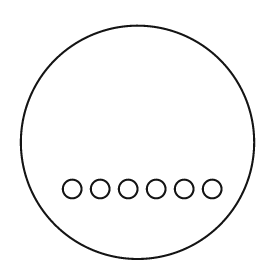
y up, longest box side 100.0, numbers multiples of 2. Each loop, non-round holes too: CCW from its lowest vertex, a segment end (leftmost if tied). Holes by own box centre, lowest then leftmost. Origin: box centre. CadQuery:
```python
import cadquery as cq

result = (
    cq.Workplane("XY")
    .moveTo(0.0, 0.0)
    .circle(50.0)
    .moveTo(-28.0, -20.0)
    .circle(4.0)
    .moveTo(-16.0, -20.0)
    .circle(4.0)
    .moveTo(-4.0, -20.0)
    .circle(4.0)
    .moveTo(8.0, -20.0)
    .circle(4.0)
    .moveTo(20.0, -20.0)
    .circle(4.0)
    .moveTo(32.0, -20.0)
    .circle(4.0)
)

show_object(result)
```